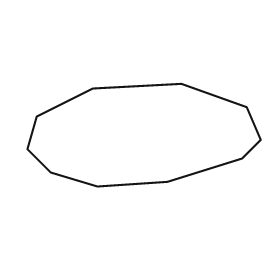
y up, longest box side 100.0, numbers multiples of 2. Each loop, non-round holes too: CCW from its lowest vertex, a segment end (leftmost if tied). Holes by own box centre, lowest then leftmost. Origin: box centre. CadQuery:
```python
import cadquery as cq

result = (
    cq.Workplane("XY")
    .moveTo(-20.0, -22.0)
    .lineTo(10.0, -20.0)
    .lineTo(42.0, -10.0)
    .lineTo(50.0, -2.0)
    .lineTo(44.0, 12.0)
    .lineTo(16.0, 22.0)
    .lineTo(-22.0, 20.0)
    .lineTo(-46.0, 8.0)
    .lineTo(-50.0, -6.0)
    .lineTo(-40.0, -16.0)
    .close()
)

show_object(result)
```